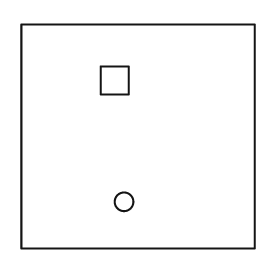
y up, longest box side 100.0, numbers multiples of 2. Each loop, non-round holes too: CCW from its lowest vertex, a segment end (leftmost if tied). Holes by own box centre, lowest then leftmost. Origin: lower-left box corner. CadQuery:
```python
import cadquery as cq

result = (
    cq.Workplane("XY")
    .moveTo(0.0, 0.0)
    .lineTo(100.0, 0.0)
    .lineTo(100.0, 96.0)
    .lineTo(0.0, 96.0)
    .close()
    .moveTo(44.0, 20.0)
    .circle(4.0)
    .moveTo(34.0, 66.0)
    .lineTo(46.0, 66.0)
    .lineTo(46.0, 78.0)
    .lineTo(34.0, 78.0)
    .close()
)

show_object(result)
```